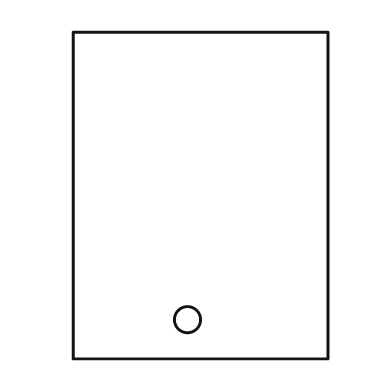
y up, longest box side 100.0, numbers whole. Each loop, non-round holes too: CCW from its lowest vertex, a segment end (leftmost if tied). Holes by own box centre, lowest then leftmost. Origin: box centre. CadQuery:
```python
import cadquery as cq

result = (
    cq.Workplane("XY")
    .moveTo(-39.0, -50.0)
    .lineTo(39.0, -50.0)
    .lineTo(39.0, 50.0)
    .lineTo(-39.0, 50.0)
    .close()
    .moveTo(-4.0, -38.0)
    .circle(4.0)
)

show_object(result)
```